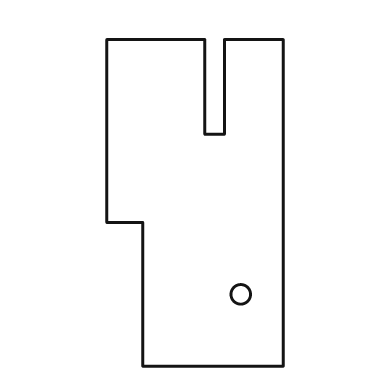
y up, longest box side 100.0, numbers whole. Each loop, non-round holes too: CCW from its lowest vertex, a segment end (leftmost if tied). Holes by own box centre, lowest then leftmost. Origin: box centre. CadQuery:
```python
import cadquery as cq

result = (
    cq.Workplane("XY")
    .moveTo(-16.0, -50.0)
    .lineTo(27.0, -50.0)
    .lineTo(27.0, 50.0)
    .lineTo(9.0, 50.0)
    .lineTo(9.0, 21.0)
    .lineTo(3.0, 21.0)
    .lineTo(3.0, 50.0)
    .lineTo(-27.0, 50.0)
    .lineTo(-27.0, -6.0)
    .lineTo(-16.0, -6.0)
    .close()
    .moveTo(14.0, -28.0)
    .circle(3.0)
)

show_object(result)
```